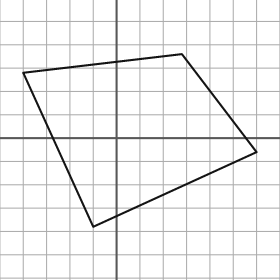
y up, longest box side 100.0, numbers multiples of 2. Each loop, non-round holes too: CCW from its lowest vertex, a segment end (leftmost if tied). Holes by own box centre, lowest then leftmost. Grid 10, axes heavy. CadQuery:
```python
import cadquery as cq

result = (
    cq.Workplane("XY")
    .moveTo(-10.0, -38.0)
    .lineTo(60.0, -6.0)
    .lineTo(28.0, 36.0)
    .lineTo(-40.0, 28.0)
    .close()
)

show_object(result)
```